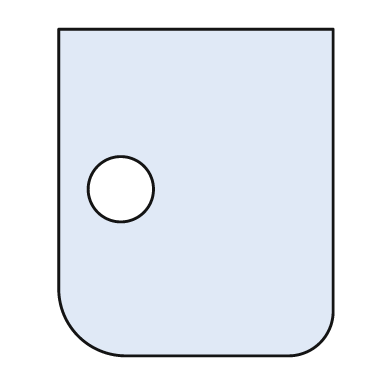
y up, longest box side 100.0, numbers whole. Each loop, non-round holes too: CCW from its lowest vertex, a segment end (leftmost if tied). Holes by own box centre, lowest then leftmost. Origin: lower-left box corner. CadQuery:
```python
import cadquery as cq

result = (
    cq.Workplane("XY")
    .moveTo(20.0, 0.0)
    .lineTo(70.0, 0.0)
    .threePointArc((80.0, 4.0), (84.0, 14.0))
    .lineTo(84.0, 100.0)
    .lineTo(0.0, 100.0)
    .lineTo(0.0, 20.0)
    .threePointArc((6.0, 6.0), (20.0, 0.0))
    .close()
    .moveTo(19.0, 51.0)
    .circle(10.0)
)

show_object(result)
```